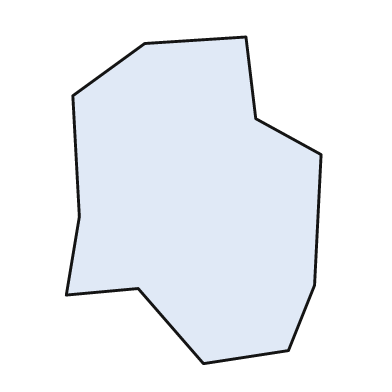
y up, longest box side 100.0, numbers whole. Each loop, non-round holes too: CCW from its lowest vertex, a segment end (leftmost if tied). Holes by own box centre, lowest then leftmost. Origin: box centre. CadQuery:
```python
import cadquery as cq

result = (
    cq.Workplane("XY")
    .moveTo(3.0, -50.0)
    .lineTo(29.0, -46.0)
    .lineTo(37.0, -26.0)
    .lineTo(39.0, 14.0)
    .lineTo(19.0, 25.0)
    .lineTo(16.0, 50.0)
    .lineTo(-15.0, 48.0)
    .lineTo(-37.0, 32.0)
    .lineTo(-35.0, -5.0)
    .lineTo(-39.0, -29.0)
    .lineTo(-17.0, -27.0)
    .close()
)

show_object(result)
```